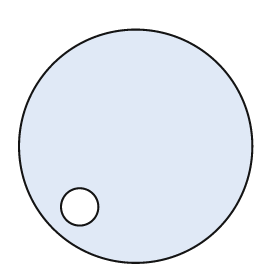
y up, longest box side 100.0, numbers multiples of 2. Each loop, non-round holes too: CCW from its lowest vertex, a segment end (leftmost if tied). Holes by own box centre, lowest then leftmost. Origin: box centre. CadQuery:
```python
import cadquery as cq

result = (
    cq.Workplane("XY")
    .moveTo(0.0, 0.0)
    .circle(50.0)
    .moveTo(-24.0, -26.0)
    .circle(8.0)
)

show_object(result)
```